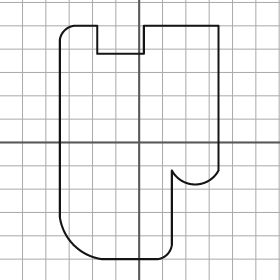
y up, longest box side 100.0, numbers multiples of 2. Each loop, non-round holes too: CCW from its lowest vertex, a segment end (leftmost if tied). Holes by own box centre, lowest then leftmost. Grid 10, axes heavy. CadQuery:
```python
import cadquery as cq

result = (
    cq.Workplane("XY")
    .moveTo(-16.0, -50.0)
    .lineTo(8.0, -50.0)
    .threePointArc((12.0, -48.0), (14.0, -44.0))
    .lineTo(14.0, -12.0)
    .threePointArc((24.0, -18.0), (34.0, -12.0))
    .lineTo(34.0, 50.0)
    .lineTo(2.0, 50.0)
    .lineTo(2.0, 38.0)
    .lineTo(-18.0, 38.0)
    .lineTo(-18.0, 50.0)
    .lineTo(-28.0, 50.0)
    .threePointArc((-32.0, 48.0), (-34.0, 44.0))
    .lineTo(-34.0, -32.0)
    .threePointArc((-28.0, -44.0), (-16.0, -50.0))
    .close()
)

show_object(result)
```